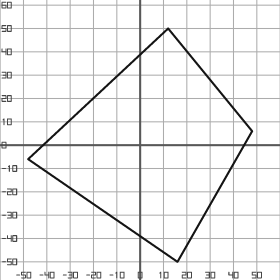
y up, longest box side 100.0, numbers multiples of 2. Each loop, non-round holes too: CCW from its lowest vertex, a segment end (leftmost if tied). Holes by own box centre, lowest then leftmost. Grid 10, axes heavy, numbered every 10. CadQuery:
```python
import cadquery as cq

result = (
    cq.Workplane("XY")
    .moveTo(16.0, -50.0)
    .lineTo(48.0, 6.0)
    .lineTo(12.0, 50.0)
    .lineTo(-48.0, -6.0)
    .close()
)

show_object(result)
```